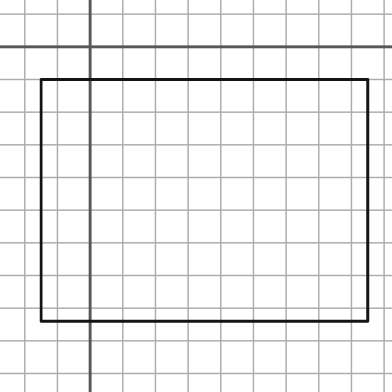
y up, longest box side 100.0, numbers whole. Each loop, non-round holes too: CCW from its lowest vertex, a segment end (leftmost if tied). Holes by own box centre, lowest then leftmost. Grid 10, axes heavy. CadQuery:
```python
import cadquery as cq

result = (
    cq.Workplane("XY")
    .moveTo(-15.0, -84.0)
    .lineTo(85.0, -84.0)
    .lineTo(85.0, -10.0)
    .lineTo(-15.0, -10.0)
    .close()
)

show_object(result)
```